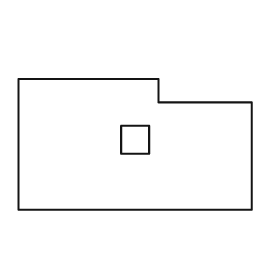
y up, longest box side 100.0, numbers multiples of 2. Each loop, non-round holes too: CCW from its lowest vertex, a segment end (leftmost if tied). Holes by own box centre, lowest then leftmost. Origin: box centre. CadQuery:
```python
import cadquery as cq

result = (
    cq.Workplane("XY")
    .moveTo(-50.0, -28.0)
    .lineTo(50.0, -28.0)
    .lineTo(50.0, 18.0)
    .lineTo(10.0, 18.0)
    .lineTo(10.0, 28.0)
    .lineTo(-50.0, 28.0)
    .close()
    .moveTo(-6.0, -4.0)
    .lineTo(6.0, -4.0)
    .lineTo(6.0, 8.0)
    .lineTo(-6.0, 8.0)
    .close()
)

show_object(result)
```